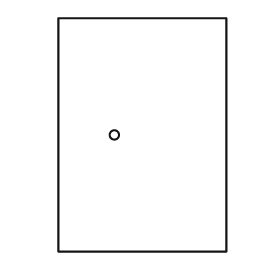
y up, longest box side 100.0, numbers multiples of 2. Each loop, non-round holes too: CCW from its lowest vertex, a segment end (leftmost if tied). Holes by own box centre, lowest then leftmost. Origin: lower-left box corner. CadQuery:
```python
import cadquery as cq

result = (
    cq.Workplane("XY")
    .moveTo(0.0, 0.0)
    .lineTo(72.0, 0.0)
    .lineTo(72.0, 100.0)
    .lineTo(0.0, 100.0)
    .close()
    .moveTo(24.0, 50.0)
    .circle(2.0)
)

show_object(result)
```